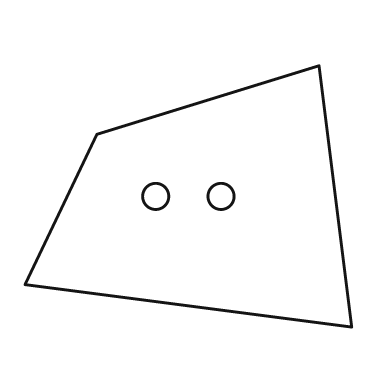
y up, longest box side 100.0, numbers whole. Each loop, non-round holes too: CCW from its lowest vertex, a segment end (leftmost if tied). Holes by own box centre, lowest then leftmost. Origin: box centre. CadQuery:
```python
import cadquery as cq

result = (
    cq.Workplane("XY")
    .moveTo(50.0, -40.0)
    .lineTo(40.0, 40.0)
    .lineTo(-28.0, 19.0)
    .lineTo(-50.0, -27.0)
    .close()
    .moveTo(-10.0, 0.0)
    .circle(4.0)
    .moveTo(10.0, 0.0)
    .circle(4.0)
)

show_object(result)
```